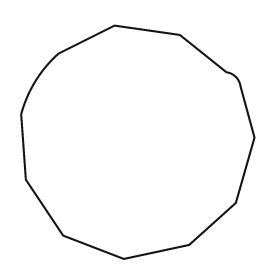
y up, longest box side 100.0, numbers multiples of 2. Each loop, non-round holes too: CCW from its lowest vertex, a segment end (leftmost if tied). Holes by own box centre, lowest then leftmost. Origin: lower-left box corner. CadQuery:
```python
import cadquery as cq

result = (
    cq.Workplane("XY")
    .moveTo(44.0, 0.0)
    .lineTo(72.0, 6.0)
    .lineTo(92.0, 24.0)
    .lineTo(100.0, 52.0)
    .lineTo(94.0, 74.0)
    .threePointArc((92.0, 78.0), (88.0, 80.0))
    .lineTo(68.0, 96.0)
    .lineTo(40.0, 100.0)
    .lineTo(16.0, 88.0)
    .threePointArc((6.0, 76.0), (0.0, 62.0))
    .lineTo(2.0, 34.0)
    .lineTo(18.0, 10.0)
    .close()
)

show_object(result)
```